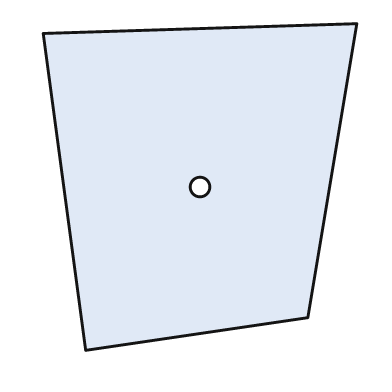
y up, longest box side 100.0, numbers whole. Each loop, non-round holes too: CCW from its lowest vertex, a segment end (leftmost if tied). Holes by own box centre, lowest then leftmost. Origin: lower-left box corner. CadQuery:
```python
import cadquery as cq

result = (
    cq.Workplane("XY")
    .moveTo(13.0, 0.0)
    .lineTo(81.0, 10.0)
    .lineTo(96.0, 100.0)
    .lineTo(0.0, 97.0)
    .close()
    .moveTo(48.0, 50.0)
    .circle(3.0)
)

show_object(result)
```